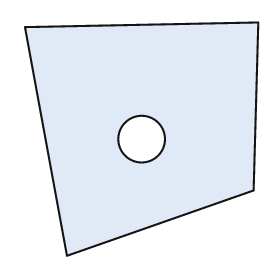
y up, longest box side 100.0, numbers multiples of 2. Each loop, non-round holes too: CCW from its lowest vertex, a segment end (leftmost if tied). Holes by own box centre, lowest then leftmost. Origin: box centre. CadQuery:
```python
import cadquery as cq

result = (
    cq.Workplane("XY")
    .moveTo(-32.0, -50.0)
    .lineTo(48.0, -22.0)
    .lineTo(50.0, 50.0)
    .lineTo(-50.0, 48.0)
    .close()
    .moveTo(0.0, 0.0)
    .circle(10.0)
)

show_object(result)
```